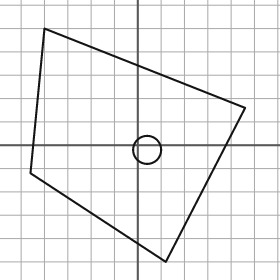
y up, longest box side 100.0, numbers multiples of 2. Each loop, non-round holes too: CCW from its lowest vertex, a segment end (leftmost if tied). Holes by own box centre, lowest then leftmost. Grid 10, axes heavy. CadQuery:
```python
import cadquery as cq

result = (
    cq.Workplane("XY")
    .moveTo(12.0, -50.0)
    .lineTo(46.0, 16.0)
    .lineTo(-40.0, 50.0)
    .lineTo(-46.0, -12.0)
    .close()
    .moveTo(4.0, -2.0)
    .circle(6.0)
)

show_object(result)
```